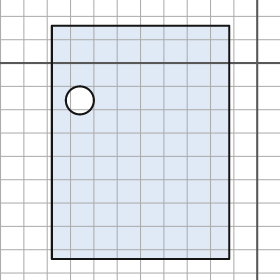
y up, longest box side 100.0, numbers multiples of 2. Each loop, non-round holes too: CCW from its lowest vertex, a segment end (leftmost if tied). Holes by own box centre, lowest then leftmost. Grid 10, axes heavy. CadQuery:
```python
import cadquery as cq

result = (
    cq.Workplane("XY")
    .moveTo(-88.0, -84.0)
    .lineTo(-12.0, -84.0)
    .lineTo(-12.0, 16.0)
    .lineTo(-88.0, 16.0)
    .close()
    .moveTo(-76.0, -16.0)
    .circle(6.0)
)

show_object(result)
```